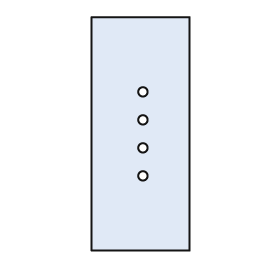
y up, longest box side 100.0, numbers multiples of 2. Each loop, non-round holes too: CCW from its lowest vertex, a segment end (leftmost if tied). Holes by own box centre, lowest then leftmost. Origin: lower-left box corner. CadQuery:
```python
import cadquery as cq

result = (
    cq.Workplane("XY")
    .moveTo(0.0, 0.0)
    .lineTo(42.0, 0.0)
    .lineTo(42.0, 100.0)
    .lineTo(0.0, 100.0)
    .close()
    .moveTo(22.0, 32.0)
    .circle(2.0)
    .moveTo(22.0, 44.0)
    .circle(2.0)
    .moveTo(22.0, 56.0)
    .circle(2.0)
    .moveTo(22.0, 68.0)
    .circle(2.0)
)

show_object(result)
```